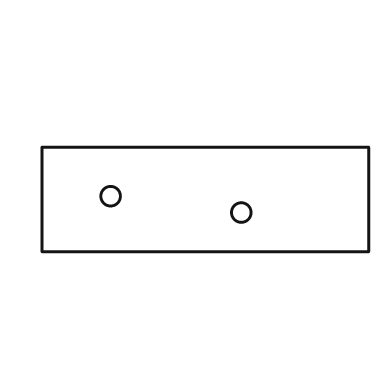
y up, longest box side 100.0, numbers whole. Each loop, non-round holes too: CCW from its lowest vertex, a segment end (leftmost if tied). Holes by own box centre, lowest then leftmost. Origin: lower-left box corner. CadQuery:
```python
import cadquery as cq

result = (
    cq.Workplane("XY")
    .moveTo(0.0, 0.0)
    .lineTo(100.0, 0.0)
    .lineTo(100.0, 32.0)
    .lineTo(0.0, 32.0)
    .close()
    .moveTo(61.0, 12.0)
    .circle(3.0)
    .moveTo(21.0, 17.0)
    .circle(3.0)
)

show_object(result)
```